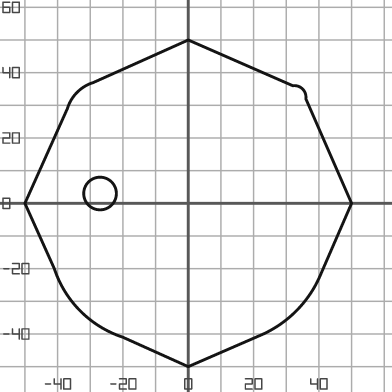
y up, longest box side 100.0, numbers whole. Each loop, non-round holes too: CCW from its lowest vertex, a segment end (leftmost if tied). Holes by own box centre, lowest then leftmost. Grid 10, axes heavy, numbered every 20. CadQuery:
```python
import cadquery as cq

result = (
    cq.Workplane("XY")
    .moveTo(0.0, -50.0)
    .lineTo(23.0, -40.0)
    .threePointArc((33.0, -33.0), (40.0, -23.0))
    .lineTo(50.0, 0.0)
    .lineTo(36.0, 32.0)
    .threePointArc((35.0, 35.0), (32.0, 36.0))
    .lineTo(0.0, 50.0)
    .lineTo(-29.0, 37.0)
    .threePointArc((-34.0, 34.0), (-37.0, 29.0))
    .lineTo(-50.0, 0.0)
    .lineTo(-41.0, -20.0)
    .threePointArc((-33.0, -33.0), (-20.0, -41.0))
    .close()
    .moveTo(-27.0, 3.0)
    .circle(5.0)
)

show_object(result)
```